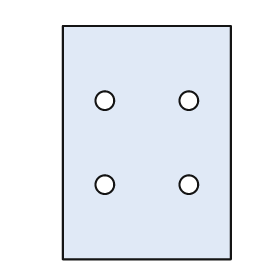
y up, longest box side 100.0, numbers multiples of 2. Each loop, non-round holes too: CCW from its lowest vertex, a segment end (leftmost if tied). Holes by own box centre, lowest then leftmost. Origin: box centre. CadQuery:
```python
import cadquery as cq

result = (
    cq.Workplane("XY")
    .moveTo(-36.0, -50.0)
    .lineTo(36.0, -50.0)
    .lineTo(36.0, 50.0)
    .lineTo(-36.0, 50.0)
    .close()
    .moveTo(-18.0, -18.0)
    .circle(4.0)
    .moveTo(18.0, -18.0)
    .circle(4.0)
    .moveTo(-18.0, 18.0)
    .circle(4.0)
    .moveTo(18.0, 18.0)
    .circle(4.0)
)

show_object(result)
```